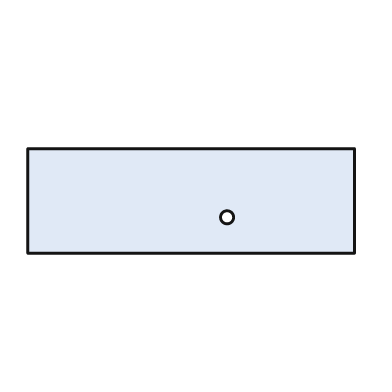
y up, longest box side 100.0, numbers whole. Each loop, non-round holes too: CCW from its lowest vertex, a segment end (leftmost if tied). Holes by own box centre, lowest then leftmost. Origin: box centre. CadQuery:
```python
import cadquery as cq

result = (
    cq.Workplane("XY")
    .moveTo(-50.0, -16.0)
    .lineTo(50.0, -16.0)
    .lineTo(50.0, 16.0)
    .lineTo(-50.0, 16.0)
    .close()
    .moveTo(11.0, -5.0)
    .circle(2.0)
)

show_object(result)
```